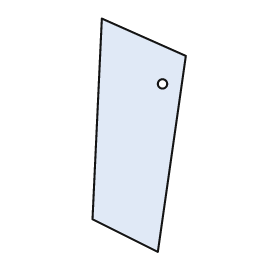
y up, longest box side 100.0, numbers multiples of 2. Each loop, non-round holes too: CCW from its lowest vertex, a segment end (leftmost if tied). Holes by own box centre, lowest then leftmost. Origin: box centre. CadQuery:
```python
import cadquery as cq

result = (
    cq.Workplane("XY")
    .moveTo(8.0, -50.0)
    .lineTo(20.0, 34.0)
    .lineTo(-16.0, 50.0)
    .lineTo(-20.0, -36.0)
    .close()
    .moveTo(10.0, 22.0)
    .circle(2.0)
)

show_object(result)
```